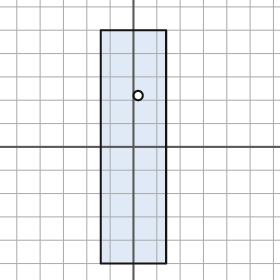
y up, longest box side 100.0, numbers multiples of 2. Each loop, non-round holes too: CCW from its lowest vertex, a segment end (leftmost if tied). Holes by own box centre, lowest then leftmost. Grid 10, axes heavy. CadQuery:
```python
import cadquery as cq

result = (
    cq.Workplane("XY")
    .moveTo(-14.0, -50.0)
    .lineTo(14.0, -50.0)
    .lineTo(14.0, 50.0)
    .lineTo(-14.0, 50.0)
    .close()
    .moveTo(2.0, 22.0)
    .circle(2.0)
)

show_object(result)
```